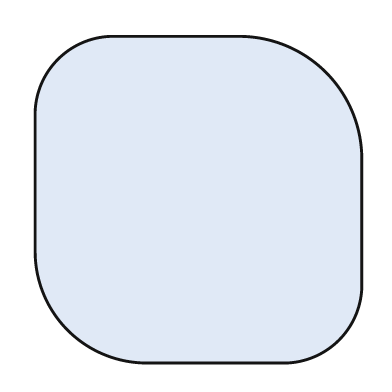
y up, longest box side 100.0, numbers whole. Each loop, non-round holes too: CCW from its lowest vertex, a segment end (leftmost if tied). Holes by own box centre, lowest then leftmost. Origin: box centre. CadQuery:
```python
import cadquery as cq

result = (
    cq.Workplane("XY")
    .moveTo(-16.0, -50.0)
    .lineTo(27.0, -50.0)
    .threePointArc((43.0, -43.0), (50.0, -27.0))
    .lineTo(50.0, 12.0)
    .threePointArc((39.0, 39.0), (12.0, 50.0))
    .lineTo(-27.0, 50.0)
    .threePointArc((-43.0, 43.0), (-50.0, 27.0))
    .lineTo(-50.0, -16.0)
    .threePointArc((-40.0, -40.0), (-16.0, -50.0))
    .close()
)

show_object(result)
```